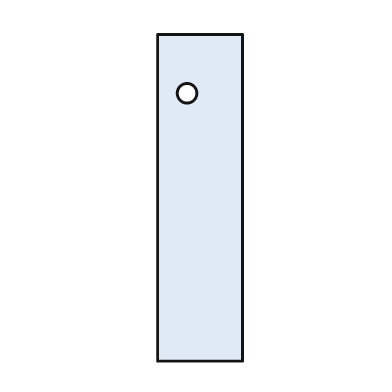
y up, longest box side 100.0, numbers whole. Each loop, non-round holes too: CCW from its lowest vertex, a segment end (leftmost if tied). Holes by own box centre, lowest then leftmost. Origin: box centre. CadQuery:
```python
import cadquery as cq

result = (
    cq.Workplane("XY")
    .moveTo(-13.0, -50.0)
    .lineTo(13.0, -50.0)
    .lineTo(13.0, 50.0)
    .lineTo(-13.0, 50.0)
    .close()
    .moveTo(-4.0, 32.0)
    .circle(3.0)
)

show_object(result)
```